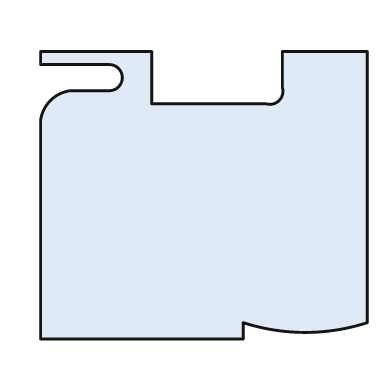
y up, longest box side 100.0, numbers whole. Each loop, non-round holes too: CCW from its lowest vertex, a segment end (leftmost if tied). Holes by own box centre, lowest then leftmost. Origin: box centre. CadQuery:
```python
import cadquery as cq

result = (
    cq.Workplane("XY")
    .moveTo(-50.0, -44.0)
    .lineTo(12.0, -44.0)
    .lineTo(12.0, -39.0)
    .threePointArc((31.0, -42.0), (50.0, -39.0))
    .lineTo(50.0, 44.0)
    .lineTo(24.0, 44.0)
    .lineTo(24.0, 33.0)
    .threePointArc((23.0, 29.0), (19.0, 28.0))
    .lineTo(-16.0, 28.0)
    .lineTo(-16.0, 44.0)
    .lineTo(-50.0, 44.0)
    .lineTo(-50.0, 40.0)
    .lineTo(-29.0, 40.0)
    .threePointArc((-25.0, 36.0), (-29.0, 32.0))
    .lineTo(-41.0, 32.0)
    .threePointArc((-47.0, 29.0), (-50.0, 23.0))
    .close()
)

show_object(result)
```